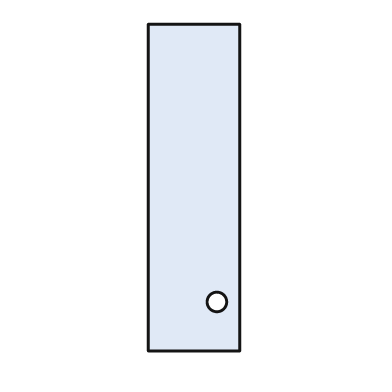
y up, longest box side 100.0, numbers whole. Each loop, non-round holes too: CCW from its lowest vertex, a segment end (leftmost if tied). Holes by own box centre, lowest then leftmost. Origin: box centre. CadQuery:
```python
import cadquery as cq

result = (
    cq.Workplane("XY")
    .moveTo(-14.0, -50.0)
    .lineTo(14.0, -50.0)
    .lineTo(14.0, 50.0)
    .lineTo(-14.0, 50.0)
    .close()
    .moveTo(7.0, -35.0)
    .circle(3.0)
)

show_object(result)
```